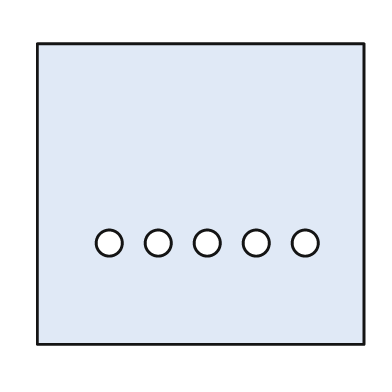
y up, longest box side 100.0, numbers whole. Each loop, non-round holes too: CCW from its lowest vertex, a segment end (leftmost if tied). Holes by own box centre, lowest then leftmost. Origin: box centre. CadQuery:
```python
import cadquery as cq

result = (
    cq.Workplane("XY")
    .moveTo(-50.0, -46.0)
    .lineTo(50.0, -46.0)
    .lineTo(50.0, 46.0)
    .lineTo(-50.0, 46.0)
    .close()
    .moveTo(-28.0, -15.0)
    .circle(4.0)
    .moveTo(-13.0, -15.0)
    .circle(4.0)
    .moveTo(2.0, -15.0)
    .circle(4.0)
    .moveTo(17.0, -15.0)
    .circle(4.0)
    .moveTo(32.0, -15.0)
    .circle(4.0)
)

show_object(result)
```